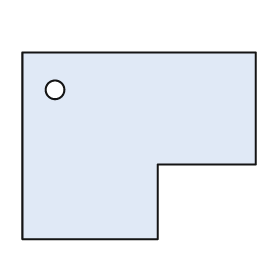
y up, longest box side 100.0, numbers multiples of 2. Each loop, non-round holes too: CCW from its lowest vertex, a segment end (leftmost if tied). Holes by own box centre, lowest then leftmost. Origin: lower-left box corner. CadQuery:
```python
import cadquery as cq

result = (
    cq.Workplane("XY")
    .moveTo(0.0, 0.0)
    .lineTo(58.0, 0.0)
    .lineTo(58.0, 32.0)
    .lineTo(100.0, 32.0)
    .lineTo(100.0, 80.0)
    .lineTo(0.0, 80.0)
    .close()
    .moveTo(14.0, 64.0)
    .circle(4.0)
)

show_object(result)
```